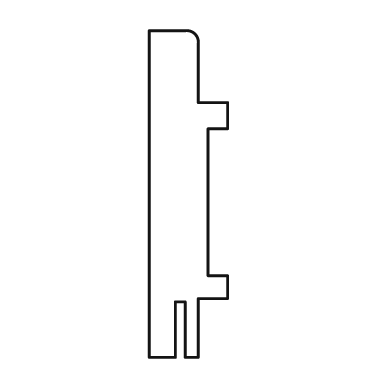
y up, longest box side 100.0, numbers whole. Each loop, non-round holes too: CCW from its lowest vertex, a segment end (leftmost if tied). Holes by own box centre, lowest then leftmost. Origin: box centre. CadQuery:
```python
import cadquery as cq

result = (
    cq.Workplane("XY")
    .moveTo(-12.0, -50.0)
    .lineTo(-4.0, -50.0)
    .lineTo(-4.0, -33.0)
    .lineTo(-1.0, -33.0)
    .lineTo(-1.0, -50.0)
    .lineTo(3.0, -50.0)
    .lineTo(3.0, -32.0)
    .lineTo(12.0, -32.0)
    .lineTo(12.0, -25.0)
    .lineTo(6.0, -25.0)
    .lineTo(6.0, 20.0)
    .lineTo(12.0, 20.0)
    .lineTo(12.0, 28.0)
    .lineTo(3.0, 28.0)
    .lineTo(3.0, 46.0)
    .threePointArc((2.0, 49.0), (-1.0, 50.0))
    .lineTo(-12.0, 50.0)
    .close()
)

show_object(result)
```